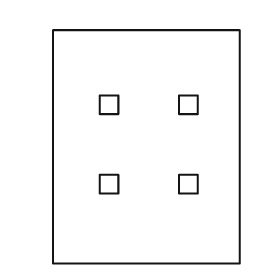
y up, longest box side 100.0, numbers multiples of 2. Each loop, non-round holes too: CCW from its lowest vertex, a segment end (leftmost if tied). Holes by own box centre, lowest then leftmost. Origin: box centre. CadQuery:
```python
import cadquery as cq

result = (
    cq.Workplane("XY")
    .moveTo(-40.0, -50.0)
    .lineTo(40.0, -50.0)
    .lineTo(40.0, 50.0)
    .lineTo(-40.0, 50.0)
    .close()
    .moveTo(-20.0, -20.0)
    .lineTo(-12.0, -20.0)
    .lineTo(-12.0, -12.0)
    .lineTo(-20.0, -12.0)
    .close()
    .moveTo(14.0, -20.0)
    .lineTo(22.0, -20.0)
    .lineTo(22.0, -12.0)
    .lineTo(14.0, -12.0)
    .close()
    .moveTo(-20.0, 14.0)
    .lineTo(-12.0, 14.0)
    .lineTo(-12.0, 22.0)
    .lineTo(-20.0, 22.0)
    .close()
    .moveTo(14.0, 14.0)
    .lineTo(22.0, 14.0)
    .lineTo(22.0, 22.0)
    .lineTo(14.0, 22.0)
    .close()
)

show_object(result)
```